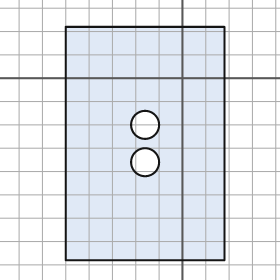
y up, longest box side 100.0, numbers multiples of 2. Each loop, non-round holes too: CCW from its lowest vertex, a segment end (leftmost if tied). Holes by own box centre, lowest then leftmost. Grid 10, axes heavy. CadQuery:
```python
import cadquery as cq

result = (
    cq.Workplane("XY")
    .moveTo(-50.0, -78.0)
    .lineTo(18.0, -78.0)
    .lineTo(18.0, 22.0)
    .lineTo(-50.0, 22.0)
    .close()
    .moveTo(-16.0, -36.0)
    .circle(6.0)
    .moveTo(-16.0, -20.0)
    .circle(6.0)
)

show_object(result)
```